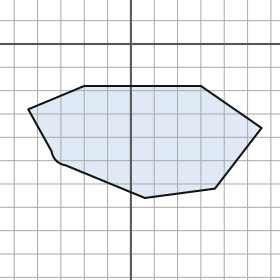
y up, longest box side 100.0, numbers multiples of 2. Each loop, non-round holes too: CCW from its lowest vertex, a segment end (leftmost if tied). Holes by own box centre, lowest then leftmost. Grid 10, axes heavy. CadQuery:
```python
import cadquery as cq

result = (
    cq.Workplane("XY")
    .moveTo(6.0, -66.0)
    .lineTo(36.0, -62.0)
    .lineTo(56.0, -36.0)
    .lineTo(30.0, -18.0)
    .lineTo(-20.0, -18.0)
    .lineTo(-44.0, -28.0)
    .lineTo(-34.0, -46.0)
    .threePointArc((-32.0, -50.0), (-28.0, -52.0))
    .close()
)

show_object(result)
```